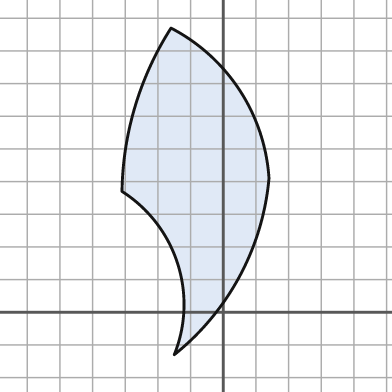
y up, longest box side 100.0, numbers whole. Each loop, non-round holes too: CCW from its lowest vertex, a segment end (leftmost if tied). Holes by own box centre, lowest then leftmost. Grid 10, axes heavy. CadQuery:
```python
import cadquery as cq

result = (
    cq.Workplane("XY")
    .moveTo(-15.0, -13.0)
    .threePointArc((5.0, 11.0), (14.0, 41.0))
    .threePointArc((5.0, 68.0), (-16.0, 87.0))
    .threePointArc((-27.0, 63.0), (-31.0, 37.0))
    .threePointArc((-14.0, 15.0), (-15.0, -13.0))
    .close()
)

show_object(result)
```